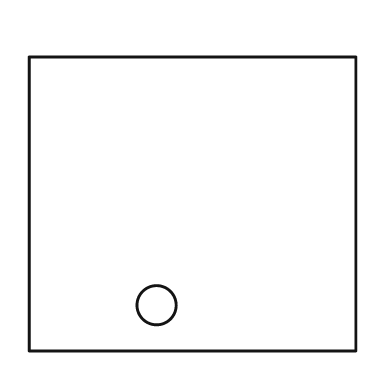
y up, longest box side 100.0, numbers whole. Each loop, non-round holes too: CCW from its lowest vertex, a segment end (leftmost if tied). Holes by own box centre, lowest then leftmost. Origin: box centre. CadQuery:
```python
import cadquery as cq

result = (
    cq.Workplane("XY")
    .moveTo(-50.0, -45.0)
    .lineTo(50.0, -45.0)
    .lineTo(50.0, 45.0)
    .lineTo(-50.0, 45.0)
    .close()
    .moveTo(-11.0, -31.0)
    .circle(6.0)
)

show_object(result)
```